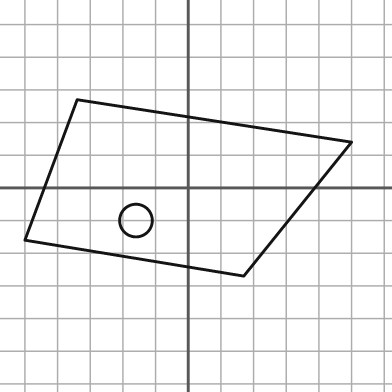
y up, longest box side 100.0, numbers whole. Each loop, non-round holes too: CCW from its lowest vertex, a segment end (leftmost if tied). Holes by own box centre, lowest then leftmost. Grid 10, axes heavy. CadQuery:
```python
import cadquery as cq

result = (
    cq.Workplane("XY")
    .moveTo(17.0, -27.0)
    .lineTo(50.0, 14.0)
    .lineTo(-34.0, 27.0)
    .lineTo(-50.0, -16.0)
    .close()
    .moveTo(-16.0, -10.0)
    .circle(5.0)
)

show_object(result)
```